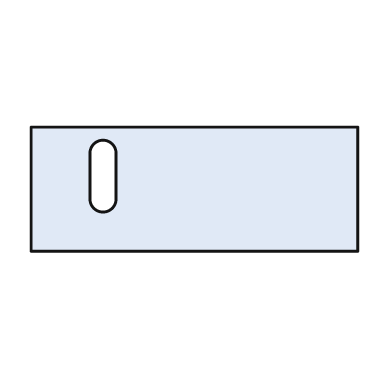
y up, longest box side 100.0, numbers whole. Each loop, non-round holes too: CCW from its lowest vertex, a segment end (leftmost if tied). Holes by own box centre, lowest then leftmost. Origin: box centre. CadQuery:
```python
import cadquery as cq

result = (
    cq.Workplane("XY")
    .moveTo(-50.0, -19.0)
    .lineTo(50.0, -19.0)
    .lineTo(50.0, 19.0)
    .lineTo(-50.0, 19.0)
    .close()
    .moveTo(-32.0, -3.0)
    .threePointArc((-28.0, -7.0), (-24.0, -3.0))
    .lineTo(-24.0, 11.0)
    .threePointArc((-28.0, 15.0), (-32.0, 11.0))
    .close()
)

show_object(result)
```